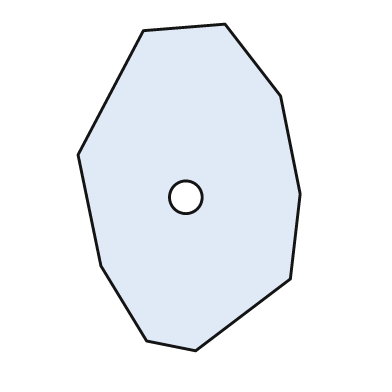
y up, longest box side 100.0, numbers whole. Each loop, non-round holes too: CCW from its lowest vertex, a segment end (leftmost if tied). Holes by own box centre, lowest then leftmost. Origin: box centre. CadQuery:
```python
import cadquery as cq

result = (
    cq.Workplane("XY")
    .moveTo(2.0, -50.0)
    .lineTo(31.0, -28.0)
    .lineTo(34.0, -2.0)
    .lineTo(28.0, 28.0)
    .lineTo(11.0, 50.0)
    .lineTo(-14.0, 48.0)
    .lineTo(-34.0, 10.0)
    .lineTo(-27.0, -24.0)
    .lineTo(-13.0, -47.0)
    .close()
    .moveTo(-1.0, -3.0)
    .circle(5.0)
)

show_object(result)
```